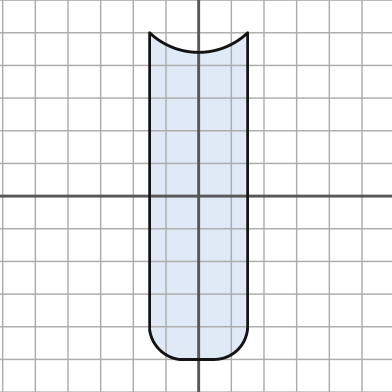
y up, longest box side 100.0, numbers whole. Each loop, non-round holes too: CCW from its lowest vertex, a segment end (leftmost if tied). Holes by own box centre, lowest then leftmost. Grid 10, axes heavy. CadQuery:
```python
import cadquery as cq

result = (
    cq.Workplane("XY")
    .moveTo(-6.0, -50.0)
    .lineTo(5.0, -50.0)
    .threePointArc((12.0, -47.0), (15.0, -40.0))
    .lineTo(15.0, 50.0)
    .threePointArc((0.0, 44.0), (-15.0, 50.0))
    .lineTo(-15.0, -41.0)
    .threePointArc((-12.0, -47.0), (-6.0, -50.0))
    .close()
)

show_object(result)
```